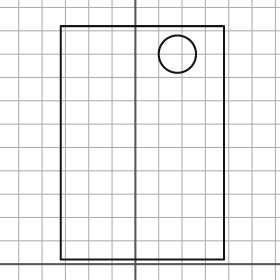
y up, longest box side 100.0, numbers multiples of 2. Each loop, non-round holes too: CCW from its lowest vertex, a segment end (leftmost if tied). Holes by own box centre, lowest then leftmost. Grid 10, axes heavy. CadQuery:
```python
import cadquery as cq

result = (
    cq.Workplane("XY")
    .moveTo(-32.0, 2.0)
    .lineTo(38.0, 2.0)
    .lineTo(38.0, 102.0)
    .lineTo(-32.0, 102.0)
    .close()
    .moveTo(18.0, 90.0)
    .circle(8.0)
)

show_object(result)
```